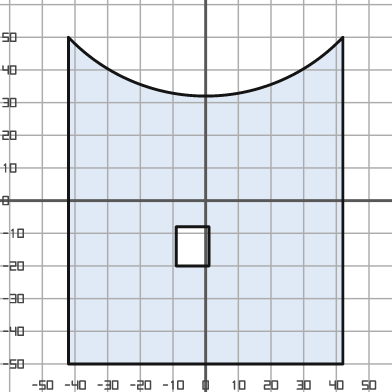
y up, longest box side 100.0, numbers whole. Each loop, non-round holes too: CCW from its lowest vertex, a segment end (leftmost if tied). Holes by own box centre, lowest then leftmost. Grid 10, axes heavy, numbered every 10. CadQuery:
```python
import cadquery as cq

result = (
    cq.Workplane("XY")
    .moveTo(-42.0, -50.0)
    .lineTo(42.0, -50.0)
    .lineTo(42.0, 50.0)
    .threePointArc((0.0, 32.0), (-42.0, 50.0))
    .close()
    .moveTo(-9.0, -20.0)
    .lineTo(1.0, -20.0)
    .lineTo(1.0, -8.0)
    .lineTo(-9.0, -8.0)
    .close()
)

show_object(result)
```